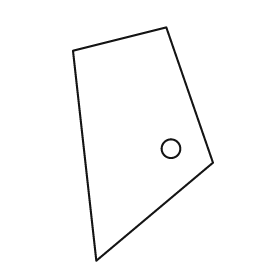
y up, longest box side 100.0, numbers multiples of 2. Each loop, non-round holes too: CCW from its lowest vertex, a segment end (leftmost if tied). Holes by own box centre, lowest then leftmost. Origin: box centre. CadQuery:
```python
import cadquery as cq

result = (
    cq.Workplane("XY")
    .moveTo(-20.0, -50.0)
    .lineTo(30.0, -8.0)
    .lineTo(10.0, 50.0)
    .lineTo(-30.0, 40.0)
    .close()
    .moveTo(12.0, -2.0)
    .circle(4.0)
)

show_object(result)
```